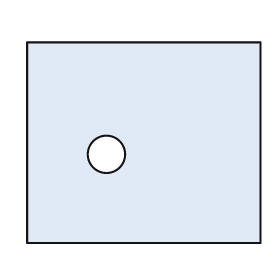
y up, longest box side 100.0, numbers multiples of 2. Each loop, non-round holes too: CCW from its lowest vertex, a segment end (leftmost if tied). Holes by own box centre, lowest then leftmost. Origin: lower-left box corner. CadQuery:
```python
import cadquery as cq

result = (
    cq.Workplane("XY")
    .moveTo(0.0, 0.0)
    .lineTo(100.0, 0.0)
    .lineTo(100.0, 86.0)
    .lineTo(0.0, 86.0)
    .close()
    .moveTo(34.0, 38.0)
    .circle(8.0)
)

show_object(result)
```